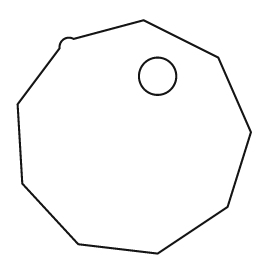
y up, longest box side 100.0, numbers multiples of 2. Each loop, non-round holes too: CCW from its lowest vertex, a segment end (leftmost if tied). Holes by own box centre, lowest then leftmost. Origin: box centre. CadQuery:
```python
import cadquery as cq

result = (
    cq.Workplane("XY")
    .moveTo(10.0, -50.0)
    .lineTo(40.0, -30.0)
    .lineTo(50.0, 2.0)
    .lineTo(36.0, 34.0)
    .lineTo(4.0, 50.0)
    .lineTo(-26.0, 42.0)
    .threePointArc((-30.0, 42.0), (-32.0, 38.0))
    .lineTo(-50.0, 14.0)
    .lineTo(-48.0, -20.0)
    .lineTo(-24.0, -46.0)
    .close()
    .moveTo(10.0, 26.0)
    .circle(8.0)
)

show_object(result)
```